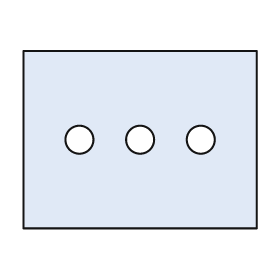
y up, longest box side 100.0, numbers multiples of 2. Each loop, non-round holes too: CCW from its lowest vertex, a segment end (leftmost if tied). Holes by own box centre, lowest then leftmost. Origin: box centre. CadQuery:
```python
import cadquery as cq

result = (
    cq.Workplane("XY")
    .moveTo(-50.0, -38.0)
    .lineTo(50.0, -38.0)
    .lineTo(50.0, 38.0)
    .lineTo(-50.0, 38.0)
    .close()
    .moveTo(-26.0, 0.0)
    .circle(6.0)
    .moveTo(0.0, 0.0)
    .circle(6.0)
    .moveTo(26.0, 0.0)
    .circle(6.0)
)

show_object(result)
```